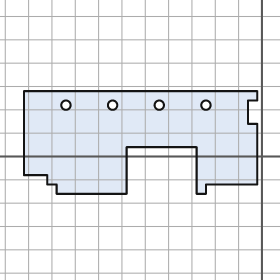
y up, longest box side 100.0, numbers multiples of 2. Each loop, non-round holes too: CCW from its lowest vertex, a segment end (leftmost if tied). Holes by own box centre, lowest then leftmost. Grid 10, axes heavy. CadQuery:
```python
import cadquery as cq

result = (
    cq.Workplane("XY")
    .moveTo(-88.0, -16.0)
    .lineTo(-58.0, -16.0)
    .lineTo(-58.0, 4.0)
    .lineTo(-28.0, 4.0)
    .lineTo(-28.0, -16.0)
    .lineTo(-24.0, -16.0)
    .lineTo(-24.0, -12.0)
    .lineTo(-2.0, -12.0)
    .lineTo(-2.0, 14.0)
    .lineTo(-6.0, 14.0)
    .lineTo(-6.0, 24.0)
    .lineTo(-2.0, 24.0)
    .lineTo(-2.0, 28.0)
    .lineTo(-102.0, 28.0)
    .lineTo(-102.0, -8.0)
    .lineTo(-92.0, -8.0)
    .lineTo(-92.0, -12.0)
    .lineTo(-88.0, -12.0)
    .close()
    .moveTo(-84.0, 22.0)
    .circle(2.0)
    .moveTo(-64.0, 22.0)
    .circle(2.0)
    .moveTo(-44.0, 22.0)
    .circle(2.0)
    .moveTo(-24.0, 22.0)
    .circle(2.0)
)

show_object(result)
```